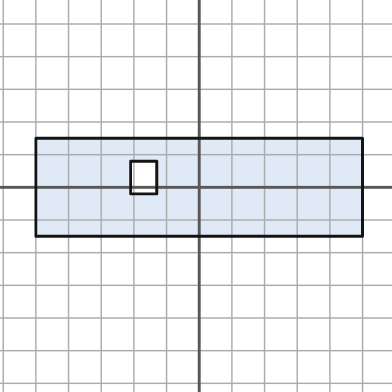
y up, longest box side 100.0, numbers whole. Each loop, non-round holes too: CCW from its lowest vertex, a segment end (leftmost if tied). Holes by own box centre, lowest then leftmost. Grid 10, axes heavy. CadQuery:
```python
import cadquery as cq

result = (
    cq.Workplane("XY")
    .moveTo(-50.0, -15.0)
    .lineTo(50.0, -15.0)
    .lineTo(50.0, 15.0)
    .lineTo(-50.0, 15.0)
    .close()
    .moveTo(-21.0, -2.0)
    .lineTo(-13.0, -2.0)
    .lineTo(-13.0, 8.0)
    .lineTo(-21.0, 8.0)
    .close()
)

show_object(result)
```